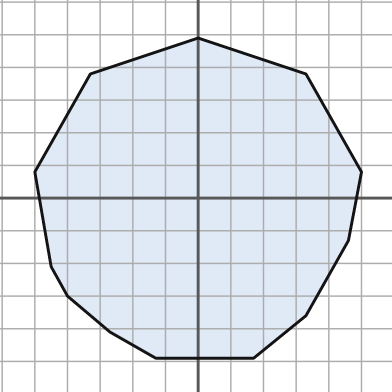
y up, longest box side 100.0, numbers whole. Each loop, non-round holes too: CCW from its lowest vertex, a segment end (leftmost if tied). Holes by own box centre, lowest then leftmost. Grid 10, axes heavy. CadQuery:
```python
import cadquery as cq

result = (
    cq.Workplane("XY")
    .moveTo(-13.0, -49.0)
    .lineTo(17.0, -49.0)
    .lineTo(33.0, -36.0)
    .lineTo(46.0, -13.0)
    .lineTo(50.0, 8.0)
    .lineTo(33.0, 38.0)
    .lineTo(0.0, 49.0)
    .lineTo(-33.0, 38.0)
    .lineTo(-50.0, 8.0)
    .lineTo(-45.0, -21.0)
    .lineTo(-40.0, -30.0)
    .lineTo(-27.0, -41.0)
    .close()
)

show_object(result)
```